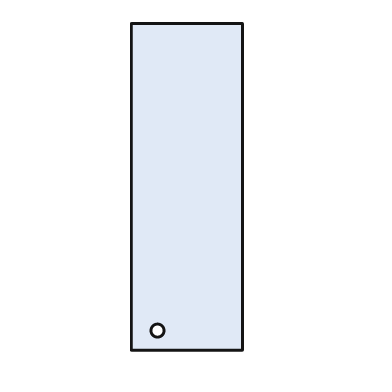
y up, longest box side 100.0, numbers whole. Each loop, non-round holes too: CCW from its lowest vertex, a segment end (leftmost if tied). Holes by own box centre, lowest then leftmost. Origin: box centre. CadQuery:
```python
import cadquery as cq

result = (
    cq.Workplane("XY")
    .moveTo(-17.0, -50.0)
    .lineTo(17.0, -50.0)
    .lineTo(17.0, 50.0)
    .lineTo(-17.0, 50.0)
    .close()
    .moveTo(-9.0, -44.0)
    .circle(2.0)
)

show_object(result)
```